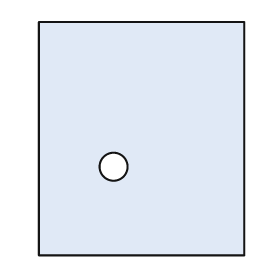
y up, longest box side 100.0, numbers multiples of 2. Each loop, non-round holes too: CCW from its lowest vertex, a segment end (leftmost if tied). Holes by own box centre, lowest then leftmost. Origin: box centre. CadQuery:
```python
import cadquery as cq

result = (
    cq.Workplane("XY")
    .moveTo(-44.0, -50.0)
    .lineTo(44.0, -50.0)
    .lineTo(44.0, 50.0)
    .lineTo(-44.0, 50.0)
    .close()
    .moveTo(-12.0, -12.0)
    .circle(6.0)
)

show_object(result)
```